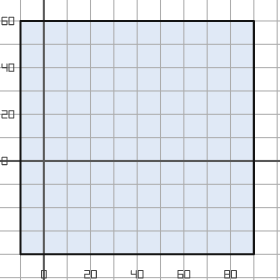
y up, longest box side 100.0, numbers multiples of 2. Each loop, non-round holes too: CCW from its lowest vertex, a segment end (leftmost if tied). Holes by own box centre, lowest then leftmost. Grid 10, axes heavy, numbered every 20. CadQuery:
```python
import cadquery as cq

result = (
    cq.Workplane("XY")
    .moveTo(-10.0, -40.0)
    .lineTo(90.0, -40.0)
    .lineTo(90.0, 60.0)
    .lineTo(-10.0, 60.0)
    .close()
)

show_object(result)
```